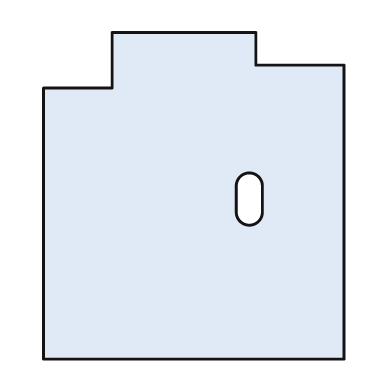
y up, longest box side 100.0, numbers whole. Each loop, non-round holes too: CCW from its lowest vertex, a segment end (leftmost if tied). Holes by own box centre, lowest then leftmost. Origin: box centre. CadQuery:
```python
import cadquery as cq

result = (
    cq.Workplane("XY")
    .moveTo(-46.0, -50.0)
    .lineTo(46.0, -50.0)
    .lineTo(46.0, 40.0)
    .lineTo(19.0, 40.0)
    .lineTo(19.0, 50.0)
    .lineTo(-25.0, 50.0)
    .lineTo(-25.0, 33.0)
    .lineTo(-46.0, 33.0)
    .close()
    .moveTo(13.0, -5.0)
    .threePointArc((17.0, -9.0), (21.0, -5.0))
    .lineTo(21.0, 3.0)
    .threePointArc((17.0, 7.0), (13.0, 3.0))
    .close()
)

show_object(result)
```